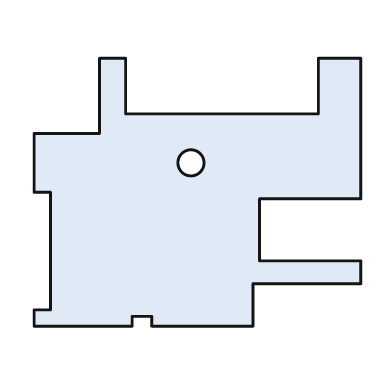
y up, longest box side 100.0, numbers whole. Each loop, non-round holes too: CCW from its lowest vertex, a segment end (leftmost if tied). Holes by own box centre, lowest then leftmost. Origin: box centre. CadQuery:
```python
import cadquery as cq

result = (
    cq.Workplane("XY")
    .moveTo(-50.0, -41.0)
    .lineTo(-20.0, -41.0)
    .lineTo(-20.0, -38.0)
    .lineTo(-14.0, -38.0)
    .lineTo(-14.0, -41.0)
    .lineTo(17.0, -41.0)
    .lineTo(17.0, -28.0)
    .lineTo(50.0, -28.0)
    .lineTo(50.0, -21.0)
    .lineTo(19.0, -21.0)
    .lineTo(19.0, -2.0)
    .lineTo(50.0, -2.0)
    .lineTo(50.0, 41.0)
    .lineTo(37.0, 41.0)
    .lineTo(37.0, 24.0)
    .lineTo(-22.0, 24.0)
    .lineTo(-22.0, 41.0)
    .lineTo(-30.0, 41.0)
    .lineTo(-30.0, 18.0)
    .lineTo(-50.0, 18.0)
    .lineTo(-50.0, 0.0)
    .lineTo(-45.0, 0.0)
    .lineTo(-45.0, -36.0)
    .lineTo(-50.0, -36.0)
    .close()
    .moveTo(-2.0, 9.0)
    .circle(4.0)
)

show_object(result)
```